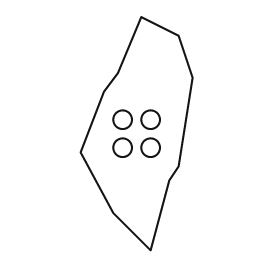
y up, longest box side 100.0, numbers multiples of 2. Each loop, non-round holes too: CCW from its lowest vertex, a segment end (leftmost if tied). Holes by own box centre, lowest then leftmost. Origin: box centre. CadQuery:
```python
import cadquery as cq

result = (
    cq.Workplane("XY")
    .moveTo(6.0, -50.0)
    .lineTo(14.0, -20.0)
    .lineTo(18.0, -14.0)
    .lineTo(24.0, 24.0)
    .lineTo(18.0, 42.0)
    .lineTo(2.0, 50.0)
    .lineTo(-8.0, 26.0)
    .lineTo(-14.0, 18.0)
    .lineTo(-24.0, -8.0)
    .lineTo(-10.0, -34.0)
    .close()
    .moveTo(-6.0, -6.0)
    .circle(4.0)
    .moveTo(6.0, -6.0)
    .circle(4.0)
    .moveTo(-6.0, 6.0)
    .circle(4.0)
    .moveTo(6.0, 6.0)
    .circle(4.0)
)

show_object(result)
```